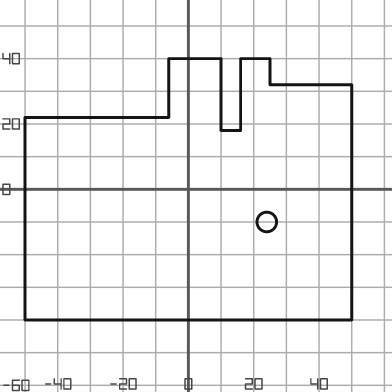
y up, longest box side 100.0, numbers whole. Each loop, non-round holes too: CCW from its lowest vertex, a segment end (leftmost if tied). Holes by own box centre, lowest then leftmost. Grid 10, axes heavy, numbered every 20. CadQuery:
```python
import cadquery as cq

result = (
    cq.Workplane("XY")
    .moveTo(-50.0, -40.0)
    .lineTo(50.0, -40.0)
    .lineTo(50.0, 32.0)
    .lineTo(25.0, 32.0)
    .lineTo(25.0, 40.0)
    .lineTo(16.0, 40.0)
    .lineTo(16.0, 18.0)
    .lineTo(10.0, 18.0)
    .lineTo(10.0, 40.0)
    .lineTo(-6.0, 40.0)
    .lineTo(-6.0, 22.0)
    .lineTo(-50.0, 22.0)
    .close()
    .moveTo(24.0, -10.0)
    .circle(3.0)
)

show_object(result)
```